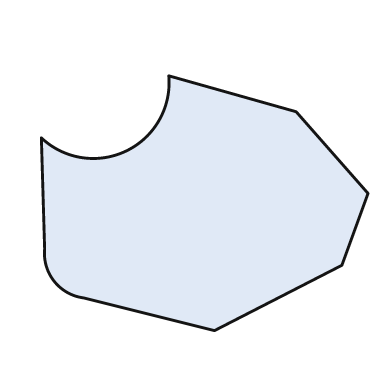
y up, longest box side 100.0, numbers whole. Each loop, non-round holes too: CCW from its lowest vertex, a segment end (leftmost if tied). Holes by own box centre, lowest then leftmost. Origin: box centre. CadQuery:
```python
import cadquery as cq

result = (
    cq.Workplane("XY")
    .moveTo(3.0, -39.0)
    .lineTo(42.0, -19.0)
    .lineTo(50.0, 3.0)
    .lineTo(28.0, 28.0)
    .lineTo(-11.0, 39.0)
    .threePointArc((-24.0, 16.0), (-50.0, 20.0))
    .lineTo(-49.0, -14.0)
    .threePointArc((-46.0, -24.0), (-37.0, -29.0))
    .close()
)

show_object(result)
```